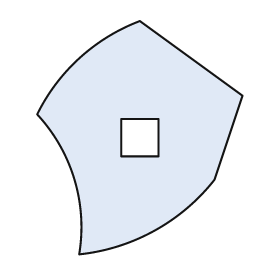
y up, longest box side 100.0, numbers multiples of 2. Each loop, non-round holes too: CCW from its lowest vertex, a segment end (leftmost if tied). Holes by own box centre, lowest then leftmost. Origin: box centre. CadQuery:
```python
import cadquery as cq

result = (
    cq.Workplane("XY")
    .moveTo(-26.0, -50.0)
    .threePointArc((6.0, -40.0), (32.0, -18.0))
    .lineTo(44.0, 18.0)
    .lineTo(0.0, 50.0)
    .threePointArc((-26.0, 34.0), (-44.0, 10.0))
    .threePointArc((-28.0, -18.0), (-26.0, -50.0))
    .close()
    .moveTo(-8.0, -8.0)
    .lineTo(8.0, -8.0)
    .lineTo(8.0, 8.0)
    .lineTo(-8.0, 8.0)
    .close()
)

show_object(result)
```